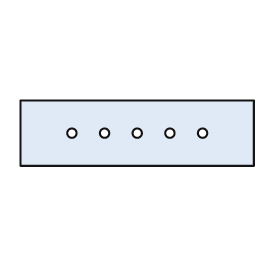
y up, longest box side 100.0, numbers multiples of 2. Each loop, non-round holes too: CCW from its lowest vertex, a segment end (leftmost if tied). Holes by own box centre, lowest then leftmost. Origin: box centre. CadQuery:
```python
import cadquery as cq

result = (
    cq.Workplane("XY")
    .moveTo(-50.0, -14.0)
    .lineTo(50.0, -14.0)
    .lineTo(50.0, 14.0)
    .lineTo(-50.0, 14.0)
    .close()
    .moveTo(-28.0, 0.0)
    .circle(2.0)
    .moveTo(-14.0, 0.0)
    .circle(2.0)
    .moveTo(0.0, 0.0)
    .circle(2.0)
    .moveTo(14.0, 0.0)
    .circle(2.0)
    .moveTo(28.0, 0.0)
    .circle(2.0)
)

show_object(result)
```